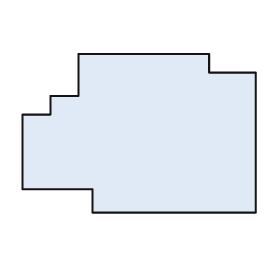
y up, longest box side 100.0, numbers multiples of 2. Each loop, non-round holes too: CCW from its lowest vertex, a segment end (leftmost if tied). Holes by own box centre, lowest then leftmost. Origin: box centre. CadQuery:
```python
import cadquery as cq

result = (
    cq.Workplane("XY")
    .moveTo(-20.0, -34.0)
    .lineTo(50.0, -34.0)
    .lineTo(50.0, 26.0)
    .lineTo(30.0, 26.0)
    .lineTo(30.0, 34.0)
    .lineTo(-26.0, 34.0)
    .lineTo(-26.0, 16.0)
    .lineTo(-38.0, 16.0)
    .lineTo(-38.0, 8.0)
    .lineTo(-50.0, 8.0)
    .lineTo(-50.0, -24.0)
    .lineTo(-20.0, -24.0)
    .close()
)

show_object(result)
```